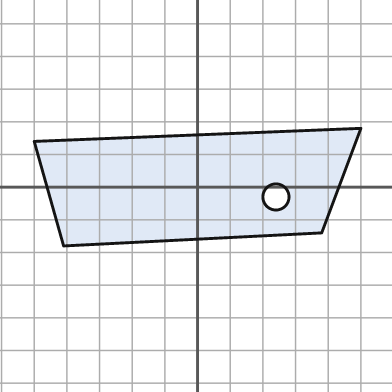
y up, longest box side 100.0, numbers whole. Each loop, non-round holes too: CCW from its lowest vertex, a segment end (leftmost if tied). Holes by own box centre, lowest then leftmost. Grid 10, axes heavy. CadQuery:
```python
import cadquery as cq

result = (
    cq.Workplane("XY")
    .moveTo(-41.0, -18.0)
    .lineTo(38.0, -14.0)
    .lineTo(50.0, 18.0)
    .lineTo(-50.0, 14.0)
    .close()
    .moveTo(24.0, -3.0)
    .circle(4.0)
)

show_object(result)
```